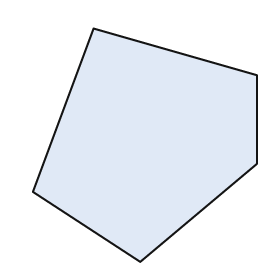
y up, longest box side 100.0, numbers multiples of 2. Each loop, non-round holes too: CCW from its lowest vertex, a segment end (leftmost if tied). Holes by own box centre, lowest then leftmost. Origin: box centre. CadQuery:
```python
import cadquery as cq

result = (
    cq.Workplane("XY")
    .moveTo(-2.0, -50.0)
    .lineTo(48.0, -8.0)
    .lineTo(48.0, 30.0)
    .lineTo(-22.0, 50.0)
    .lineTo(-48.0, -20.0)
    .close()
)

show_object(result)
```